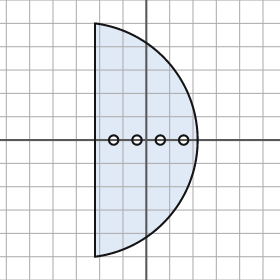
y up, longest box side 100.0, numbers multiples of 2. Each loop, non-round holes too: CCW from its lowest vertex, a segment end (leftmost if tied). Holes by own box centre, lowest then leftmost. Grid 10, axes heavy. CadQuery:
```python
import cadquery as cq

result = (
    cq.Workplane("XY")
    .moveTo(-22.0, -50.0)
    .threePointArc((22.0, 0.0), (-22.0, 50.0))
    .close()
    .moveTo(-14.0, 0.0)
    .circle(2.0)
    .moveTo(-4.0, 0.0)
    .circle(2.0)
    .moveTo(6.0, 0.0)
    .circle(2.0)
    .moveTo(16.0, 0.0)
    .circle(2.0)
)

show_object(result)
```